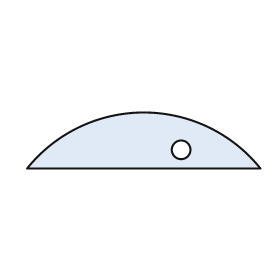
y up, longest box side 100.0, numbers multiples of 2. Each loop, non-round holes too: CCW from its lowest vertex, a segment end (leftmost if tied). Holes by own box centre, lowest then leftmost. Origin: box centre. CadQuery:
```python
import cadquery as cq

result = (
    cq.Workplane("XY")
    .moveTo(-50.0, -12.0)
    .lineTo(50.0, -12.0)
    .threePointArc((0.0, 12.0), (-50.0, -12.0))
    .close()
    .moveTo(16.0, -4.0)
    .circle(4.0)
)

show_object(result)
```